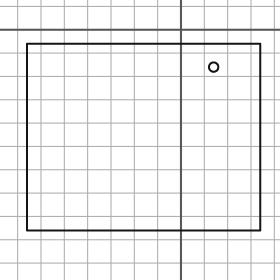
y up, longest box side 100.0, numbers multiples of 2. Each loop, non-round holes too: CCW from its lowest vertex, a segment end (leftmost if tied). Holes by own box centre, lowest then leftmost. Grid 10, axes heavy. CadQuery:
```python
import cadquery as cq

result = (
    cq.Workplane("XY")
    .moveTo(-66.0, -86.0)
    .lineTo(34.0, -86.0)
    .lineTo(34.0, -6.0)
    .lineTo(-66.0, -6.0)
    .close()
    .moveTo(14.0, -16.0)
    .circle(2.0)
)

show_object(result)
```